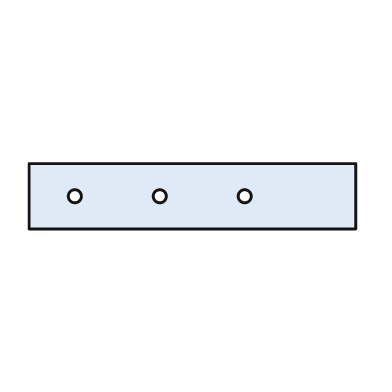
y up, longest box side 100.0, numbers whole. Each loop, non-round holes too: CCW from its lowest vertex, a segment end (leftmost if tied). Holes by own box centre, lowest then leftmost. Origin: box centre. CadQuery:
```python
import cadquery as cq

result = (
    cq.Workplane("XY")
    .moveTo(-50.0, -10.0)
    .lineTo(50.0, -10.0)
    .lineTo(50.0, 10.0)
    .lineTo(-50.0, 10.0)
    .close()
    .moveTo(-36.0, 0.0)
    .circle(2.0)
    .moveTo(-10.0, 0.0)
    .circle(2.0)
    .moveTo(16.0, 0.0)
    .circle(2.0)
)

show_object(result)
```